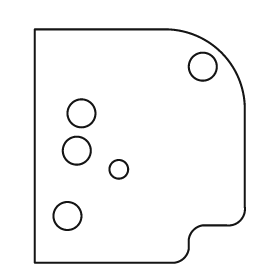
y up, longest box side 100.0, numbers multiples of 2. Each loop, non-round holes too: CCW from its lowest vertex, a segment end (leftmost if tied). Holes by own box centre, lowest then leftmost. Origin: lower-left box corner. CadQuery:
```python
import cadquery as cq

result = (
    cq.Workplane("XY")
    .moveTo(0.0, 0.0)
    .lineTo(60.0, 0.0)
    .threePointArc((64.0, 2.0), (66.0, 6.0))
    .lineTo(66.0, 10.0)
    .threePointArc((68.0, 14.0), (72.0, 16.0))
    .lineTo(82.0, 16.0)
    .threePointArc((88.0, 18.0), (90.0, 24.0))
    .lineTo(90.0, 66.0)
    .threePointArc((80.0, 90.0), (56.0, 100.0))
    .lineTo(0.0, 100.0)
    .close()
    .moveTo(14.0, 20.0)
    .circle(6.0)
    .moveTo(36.0, 40.0)
    .circle(4.0)
    .moveTo(18.0, 48.0)
    .circle(6.0)
    .moveTo(20.0, 64.0)
    .circle(6.0)
    .moveTo(72.0, 84.0)
    .circle(6.0)
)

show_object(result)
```